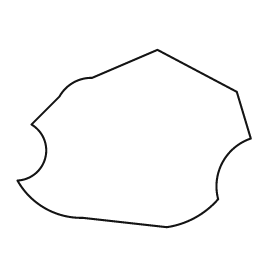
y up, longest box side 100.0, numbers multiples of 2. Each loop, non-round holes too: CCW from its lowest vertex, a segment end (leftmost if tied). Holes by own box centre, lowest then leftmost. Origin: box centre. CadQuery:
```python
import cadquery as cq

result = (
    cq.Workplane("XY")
    .moveTo(14.0, -38.0)
    .threePointArc((26.0, -34.0), (36.0, -26.0))
    .threePointArc((38.0, -10.0), (50.0, 0.0))
    .lineTo(44.0, 20.0)
    .lineTo(10.0, 38.0)
    .lineTo(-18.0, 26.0)
    .threePointArc((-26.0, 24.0), (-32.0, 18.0))
    .lineTo(-44.0, 6.0)
    .threePointArc((-38.0, -8.0), (-50.0, -18.0))
    .threePointArc((-38.0, -30.0), (-22.0, -34.0))
    .close()
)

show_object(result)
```